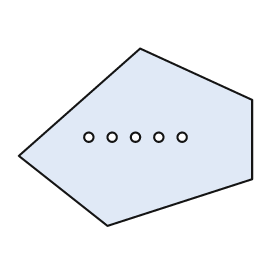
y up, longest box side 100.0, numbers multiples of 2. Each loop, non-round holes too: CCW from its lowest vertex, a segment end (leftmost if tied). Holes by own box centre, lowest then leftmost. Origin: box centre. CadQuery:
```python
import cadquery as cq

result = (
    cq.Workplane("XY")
    .moveTo(-12.0, -38.0)
    .lineTo(50.0, -18.0)
    .lineTo(50.0, 16.0)
    .lineTo(2.0, 38.0)
    .lineTo(-50.0, -8.0)
    .close()
    .moveTo(-20.0, 0.0)
    .circle(2.0)
    .moveTo(-10.0, 0.0)
    .circle(2.0)
    .moveTo(0.0, 0.0)
    .circle(2.0)
    .moveTo(10.0, 0.0)
    .circle(2.0)
    .moveTo(20.0, 0.0)
    .circle(2.0)
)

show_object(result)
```